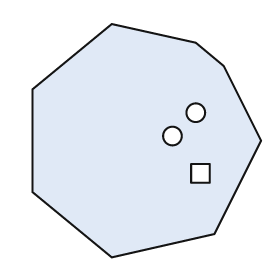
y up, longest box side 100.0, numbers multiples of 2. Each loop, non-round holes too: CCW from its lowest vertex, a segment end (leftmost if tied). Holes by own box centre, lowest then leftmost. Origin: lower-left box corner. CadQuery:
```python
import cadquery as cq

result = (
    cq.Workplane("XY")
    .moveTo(34.0, 0.0)
    .lineTo(78.0, 10.0)
    .lineTo(98.0, 50.0)
    .lineTo(82.0, 82.0)
    .lineTo(70.0, 92.0)
    .lineTo(34.0, 100.0)
    .lineTo(0.0, 72.0)
    .lineTo(0.0, 28.0)
    .close()
    .moveTo(68.0, 32.0)
    .lineTo(76.0, 32.0)
    .lineTo(76.0, 40.0)
    .lineTo(68.0, 40.0)
    .close()
    .moveTo(60.0, 52.0)
    .circle(4.0)
    .moveTo(70.0, 62.0)
    .circle(4.0)
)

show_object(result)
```